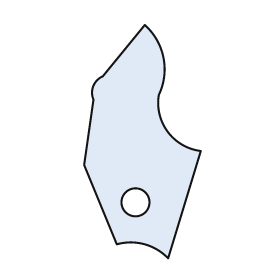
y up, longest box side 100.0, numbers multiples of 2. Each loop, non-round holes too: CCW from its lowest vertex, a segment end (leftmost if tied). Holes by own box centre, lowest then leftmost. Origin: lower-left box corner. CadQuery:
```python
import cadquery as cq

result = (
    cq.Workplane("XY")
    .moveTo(36.0, 0.0)
    .lineTo(50.0, 46.0)
    .threePointArc((36.0, 54.0), (32.0, 70.0))
    .threePointArc((34.0, 86.0), (26.0, 100.0))
    .lineTo(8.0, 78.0)
    .threePointArc((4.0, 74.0), (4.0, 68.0))
    .lineTo(0.0, 40.0)
    .lineTo(14.0, 6.0)
    .threePointArc((26.0, 6.0), (36.0, 0.0))
    .close()
    .moveTo(22.0, 24.0)
    .circle(6.0)
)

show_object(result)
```